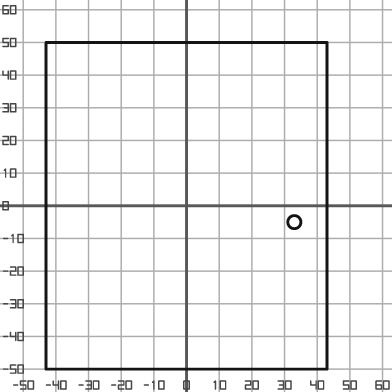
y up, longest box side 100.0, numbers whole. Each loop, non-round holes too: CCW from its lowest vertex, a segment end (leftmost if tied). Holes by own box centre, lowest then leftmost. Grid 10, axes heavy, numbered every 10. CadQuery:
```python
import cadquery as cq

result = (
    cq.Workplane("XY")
    .moveTo(-43.0, -50.0)
    .lineTo(43.0, -50.0)
    .lineTo(43.0, 50.0)
    .lineTo(-43.0, 50.0)
    .close()
    .moveTo(33.0, -5.0)
    .circle(2.0)
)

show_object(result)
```